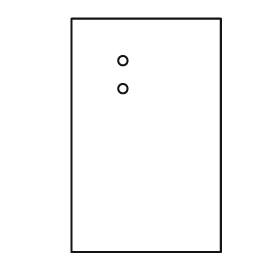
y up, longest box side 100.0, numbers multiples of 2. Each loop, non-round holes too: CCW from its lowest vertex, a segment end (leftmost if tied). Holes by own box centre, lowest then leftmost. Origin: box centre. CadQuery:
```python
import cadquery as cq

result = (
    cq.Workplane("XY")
    .moveTo(-32.0, -50.0)
    .lineTo(32.0, -50.0)
    .lineTo(32.0, 50.0)
    .lineTo(-32.0, 50.0)
    .close()
    .moveTo(-10.0, 20.0)
    .circle(2.0)
    .moveTo(-10.0, 32.0)
    .circle(2.0)
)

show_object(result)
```